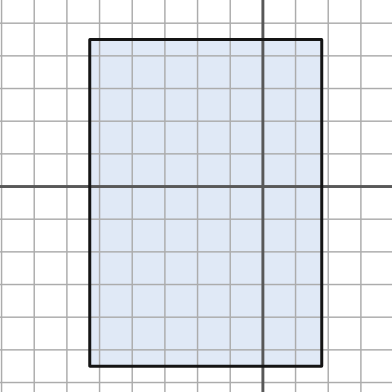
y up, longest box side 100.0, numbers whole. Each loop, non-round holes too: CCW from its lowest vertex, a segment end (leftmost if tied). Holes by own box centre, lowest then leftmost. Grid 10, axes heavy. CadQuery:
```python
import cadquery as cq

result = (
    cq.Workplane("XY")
    .moveTo(-53.0, -55.0)
    .lineTo(18.0, -55.0)
    .lineTo(18.0, 45.0)
    .lineTo(-53.0, 45.0)
    .close()
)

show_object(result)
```